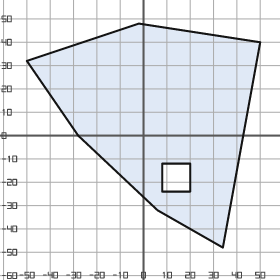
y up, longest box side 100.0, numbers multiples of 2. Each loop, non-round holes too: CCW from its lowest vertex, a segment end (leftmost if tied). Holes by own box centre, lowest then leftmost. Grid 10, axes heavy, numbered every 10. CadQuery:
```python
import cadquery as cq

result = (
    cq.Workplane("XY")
    .moveTo(34.0, -48.0)
    .lineTo(50.0, 40.0)
    .lineTo(-2.0, 48.0)
    .lineTo(-50.0, 32.0)
    .lineTo(-28.0, 0.0)
    .lineTo(6.0, -32.0)
    .close()
    .moveTo(8.0, -24.0)
    .lineTo(20.0, -24.0)
    .lineTo(20.0, -12.0)
    .lineTo(8.0, -12.0)
    .close()
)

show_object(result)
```